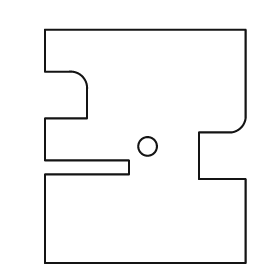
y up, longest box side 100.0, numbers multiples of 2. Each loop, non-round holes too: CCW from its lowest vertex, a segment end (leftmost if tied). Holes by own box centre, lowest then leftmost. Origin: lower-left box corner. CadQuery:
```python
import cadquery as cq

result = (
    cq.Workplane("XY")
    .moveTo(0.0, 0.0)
    .lineTo(86.0, 0.0)
    .lineTo(86.0, 36.0)
    .lineTo(66.0, 36.0)
    .lineTo(66.0, 56.0)
    .lineTo(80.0, 56.0)
    .threePointArc((84.0, 58.0), (86.0, 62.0))
    .lineTo(86.0, 100.0)
    .lineTo(0.0, 100.0)
    .lineTo(0.0, 82.0)
    .lineTo(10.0, 82.0)
    .threePointArc((16.0, 80.0), (18.0, 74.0))
    .lineTo(18.0, 62.0)
    .lineTo(0.0, 62.0)
    .lineTo(0.0, 44.0)
    .lineTo(36.0, 44.0)
    .lineTo(36.0, 38.0)
    .lineTo(0.0, 38.0)
    .close()
    .moveTo(44.0, 50.0)
    .circle(4.0)
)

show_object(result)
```